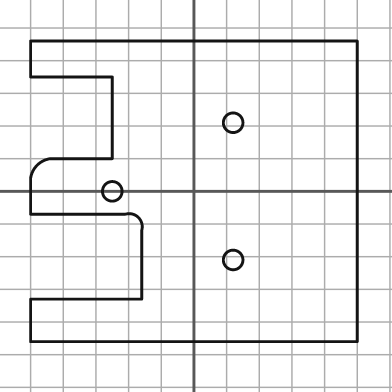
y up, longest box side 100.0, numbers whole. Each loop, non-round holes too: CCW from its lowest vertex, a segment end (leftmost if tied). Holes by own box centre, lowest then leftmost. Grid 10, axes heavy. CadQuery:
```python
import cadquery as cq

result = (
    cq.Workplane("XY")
    .moveTo(-50.0, -46.0)
    .lineTo(50.0, -46.0)
    .lineTo(50.0, 46.0)
    .lineTo(-50.0, 46.0)
    .lineTo(-50.0, 35.0)
    .lineTo(-25.0, 35.0)
    .lineTo(-25.0, 10.0)
    .lineTo(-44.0, 10.0)
    .threePointArc((-48.0, 8.0), (-50.0, 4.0))
    .lineTo(-50.0, -7.0)
    .lineTo(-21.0, -7.0)
    .threePointArc((-17.0, -8.0), (-16.0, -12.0))
    .lineTo(-16.0, -33.0)
    .lineTo(-50.0, -33.0)
    .close()
    .moveTo(12.0, -21.0)
    .circle(3.0)
    .moveTo(-25.0, 0.0)
    .circle(3.0)
    .moveTo(12.0, 21.0)
    .circle(3.0)
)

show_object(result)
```